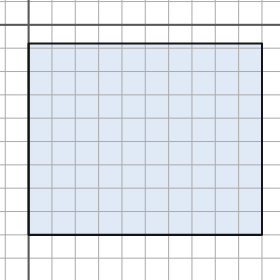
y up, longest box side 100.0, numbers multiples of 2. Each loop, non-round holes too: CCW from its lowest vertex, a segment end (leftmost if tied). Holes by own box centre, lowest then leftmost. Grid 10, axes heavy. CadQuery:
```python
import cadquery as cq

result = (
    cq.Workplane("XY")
    .moveTo(0.0, -90.0)
    .lineTo(100.0, -90.0)
    .lineTo(100.0, -8.0)
    .lineTo(0.0, -8.0)
    .close()
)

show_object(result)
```